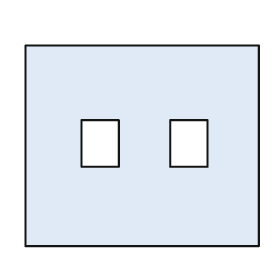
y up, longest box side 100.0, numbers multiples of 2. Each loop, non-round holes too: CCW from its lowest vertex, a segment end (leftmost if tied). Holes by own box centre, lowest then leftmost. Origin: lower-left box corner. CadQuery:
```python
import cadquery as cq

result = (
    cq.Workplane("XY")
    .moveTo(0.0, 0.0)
    .lineTo(100.0, 0.0)
    .lineTo(100.0, 86.0)
    .lineTo(0.0, 86.0)
    .close()
    .moveTo(24.0, 34.0)
    .lineTo(40.0, 34.0)
    .lineTo(40.0, 54.0)
    .lineTo(24.0, 54.0)
    .close()
    .moveTo(62.0, 34.0)
    .lineTo(78.0, 34.0)
    .lineTo(78.0, 54.0)
    .lineTo(62.0, 54.0)
    .close()
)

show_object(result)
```